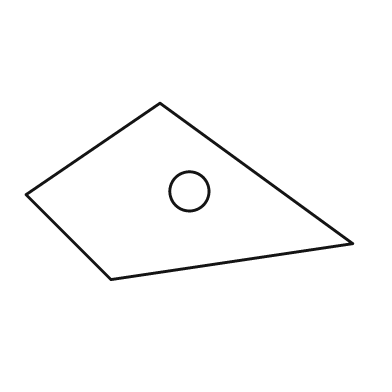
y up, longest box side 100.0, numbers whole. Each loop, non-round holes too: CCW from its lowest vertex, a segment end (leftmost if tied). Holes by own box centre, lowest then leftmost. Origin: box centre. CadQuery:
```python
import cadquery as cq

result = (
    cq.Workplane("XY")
    .moveTo(-24.0, -27.0)
    .lineTo(50.0, -16.0)
    .lineTo(-9.0, 27.0)
    .lineTo(-50.0, -1.0)
    .close()
    .moveTo(0.0, 0.0)
    .circle(6.0)
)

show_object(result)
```